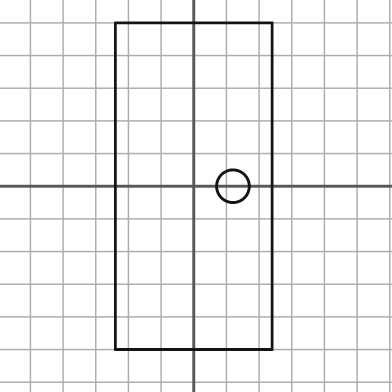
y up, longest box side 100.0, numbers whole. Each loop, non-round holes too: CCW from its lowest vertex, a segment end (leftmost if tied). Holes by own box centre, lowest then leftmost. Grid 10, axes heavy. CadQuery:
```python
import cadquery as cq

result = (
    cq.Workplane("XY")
    .moveTo(-24.0, -50.0)
    .lineTo(24.0, -50.0)
    .lineTo(24.0, 50.0)
    .lineTo(-24.0, 50.0)
    .close()
    .moveTo(12.0, 0.0)
    .circle(5.0)
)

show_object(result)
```